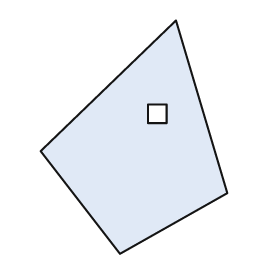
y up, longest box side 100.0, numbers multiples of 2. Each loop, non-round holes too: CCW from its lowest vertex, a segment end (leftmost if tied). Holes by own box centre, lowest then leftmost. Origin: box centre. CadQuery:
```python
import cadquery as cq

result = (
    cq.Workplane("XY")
    .moveTo(-6.0, -50.0)
    .lineTo(40.0, -24.0)
    .lineTo(18.0, 50.0)
    .lineTo(-40.0, -6.0)
    .close()
    .moveTo(6.0, 6.0)
    .lineTo(14.0, 6.0)
    .lineTo(14.0, 14.0)
    .lineTo(6.0, 14.0)
    .close()
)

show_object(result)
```